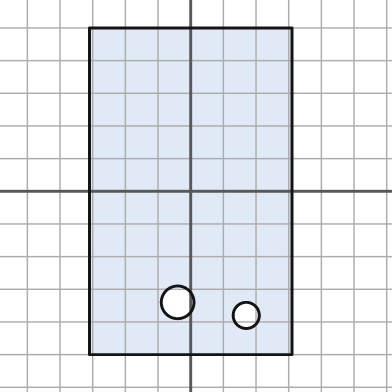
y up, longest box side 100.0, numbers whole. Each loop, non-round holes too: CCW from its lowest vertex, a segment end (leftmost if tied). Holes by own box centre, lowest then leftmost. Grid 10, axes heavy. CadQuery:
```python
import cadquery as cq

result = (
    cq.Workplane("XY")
    .moveTo(-31.0, -50.0)
    .lineTo(31.0, -50.0)
    .lineTo(31.0, 50.0)
    .lineTo(-31.0, 50.0)
    .close()
    .moveTo(17.0, -38.0)
    .circle(4.0)
    .moveTo(-4.0, -34.0)
    .circle(5.0)
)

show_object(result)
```